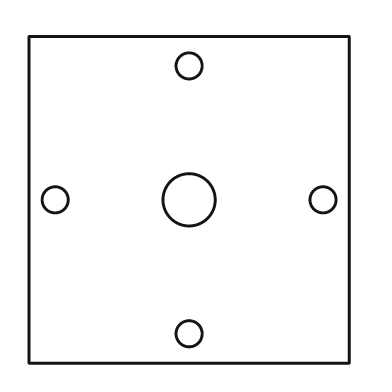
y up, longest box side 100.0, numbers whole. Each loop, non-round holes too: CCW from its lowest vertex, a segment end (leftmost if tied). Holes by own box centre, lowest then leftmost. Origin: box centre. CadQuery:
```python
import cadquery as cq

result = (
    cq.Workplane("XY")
    .moveTo(-49.0, -50.0)
    .lineTo(49.0, -50.0)
    .lineTo(49.0, 50.0)
    .lineTo(-49.0, 50.0)
    .close()
    .moveTo(0.0, -41.0)
    .circle(4.0)
    .moveTo(-41.0, 0.0)
    .circle(4.0)
    .moveTo(0.0, 0.0)
    .circle(8.0)
    .moveTo(41.0, 0.0)
    .circle(4.0)
    .moveTo(0.0, 41.0)
    .circle(4.0)
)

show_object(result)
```